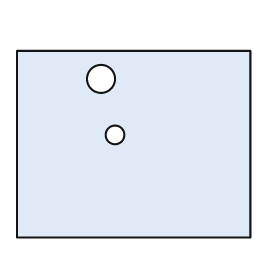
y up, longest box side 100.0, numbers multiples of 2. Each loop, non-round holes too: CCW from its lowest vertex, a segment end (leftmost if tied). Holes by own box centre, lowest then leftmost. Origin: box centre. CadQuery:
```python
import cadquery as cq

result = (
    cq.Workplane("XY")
    .moveTo(-50.0, -40.0)
    .lineTo(50.0, -40.0)
    .lineTo(50.0, 40.0)
    .lineTo(-50.0, 40.0)
    .close()
    .moveTo(-8.0, 4.0)
    .circle(4.0)
    .moveTo(-14.0, 28.0)
    .circle(6.0)
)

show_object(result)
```